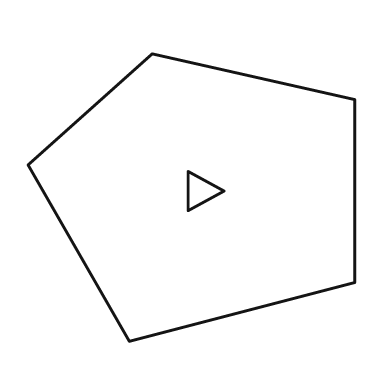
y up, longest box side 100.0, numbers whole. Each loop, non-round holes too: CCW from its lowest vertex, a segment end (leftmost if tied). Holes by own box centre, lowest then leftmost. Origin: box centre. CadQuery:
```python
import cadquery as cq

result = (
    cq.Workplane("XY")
    .moveTo(-19.0, -44.0)
    .lineTo(50.0, -26.0)
    .lineTo(50.0, 30.0)
    .lineTo(-12.0, 44.0)
    .lineTo(-50.0, 10.0)
    .close()
    .moveTo(-1.0, -4.0)
    .lineTo(10.0, 2.0)
    .lineTo(-1.0, 8.0)
    .close()
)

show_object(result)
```